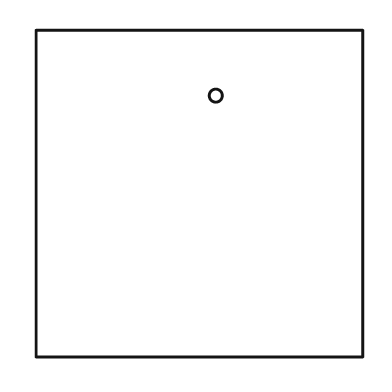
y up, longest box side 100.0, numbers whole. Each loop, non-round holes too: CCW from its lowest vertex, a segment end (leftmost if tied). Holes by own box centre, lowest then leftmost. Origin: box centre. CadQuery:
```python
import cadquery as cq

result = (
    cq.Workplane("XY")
    .moveTo(-50.0, -50.0)
    .lineTo(50.0, -50.0)
    .lineTo(50.0, 50.0)
    .lineTo(-50.0, 50.0)
    .close()
    .moveTo(5.0, 30.0)
    .circle(2.0)
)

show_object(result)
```